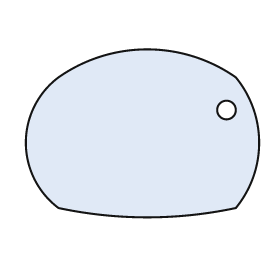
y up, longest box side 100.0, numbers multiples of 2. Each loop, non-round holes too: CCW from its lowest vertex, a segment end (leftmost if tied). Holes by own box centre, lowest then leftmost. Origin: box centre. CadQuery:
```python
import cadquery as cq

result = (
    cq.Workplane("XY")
    .moveTo(-36.0, -32.0)
    .threePointArc((2.0, -36.0), (40.0, -32.0))
    .threePointArc((50.0, -4.0), (40.0, 24.0))
    .threePointArc((2.0, 36.0), (-36.0, 24.0))
    .threePointArc((-50.0, -4.0), (-36.0, -32.0))
    .close()
    .moveTo(36.0, 10.0)
    .circle(4.0)
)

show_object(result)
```